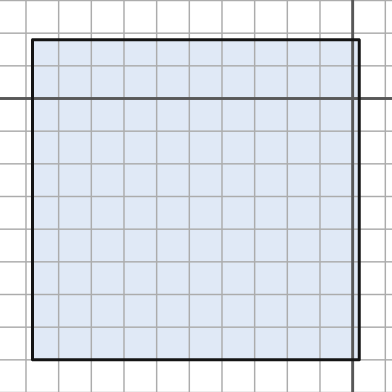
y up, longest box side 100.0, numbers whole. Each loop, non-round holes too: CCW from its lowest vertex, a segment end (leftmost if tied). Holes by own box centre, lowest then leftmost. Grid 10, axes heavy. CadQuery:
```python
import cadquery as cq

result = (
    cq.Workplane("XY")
    .moveTo(-98.0, -80.0)
    .lineTo(2.0, -80.0)
    .lineTo(2.0, 18.0)
    .lineTo(-98.0, 18.0)
    .close()
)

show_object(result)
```